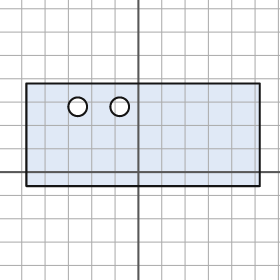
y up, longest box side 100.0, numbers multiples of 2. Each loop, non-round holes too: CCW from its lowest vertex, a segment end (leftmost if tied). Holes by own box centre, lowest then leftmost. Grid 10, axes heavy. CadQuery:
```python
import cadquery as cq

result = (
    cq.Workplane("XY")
    .moveTo(-48.0, -6.0)
    .lineTo(52.0, -6.0)
    .lineTo(52.0, 38.0)
    .lineTo(-48.0, 38.0)
    .close()
    .moveTo(-26.0, 28.0)
    .circle(4.0)
    .moveTo(-8.0, 28.0)
    .circle(4.0)
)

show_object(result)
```